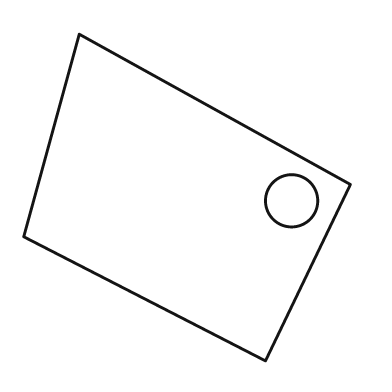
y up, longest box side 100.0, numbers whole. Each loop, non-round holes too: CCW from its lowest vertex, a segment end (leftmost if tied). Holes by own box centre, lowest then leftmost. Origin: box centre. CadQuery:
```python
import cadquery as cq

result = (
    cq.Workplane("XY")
    .moveTo(24.0, -50.0)
    .lineTo(50.0, 4.0)
    .lineTo(-33.0, 50.0)
    .lineTo(-50.0, -12.0)
    .close()
    .moveTo(32.0, -1.0)
    .circle(8.0)
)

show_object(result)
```